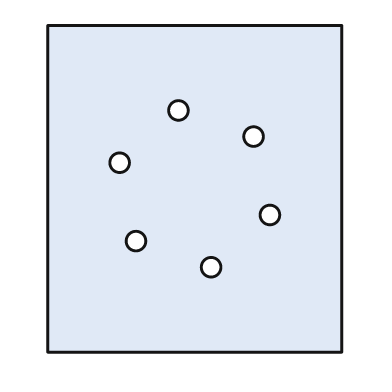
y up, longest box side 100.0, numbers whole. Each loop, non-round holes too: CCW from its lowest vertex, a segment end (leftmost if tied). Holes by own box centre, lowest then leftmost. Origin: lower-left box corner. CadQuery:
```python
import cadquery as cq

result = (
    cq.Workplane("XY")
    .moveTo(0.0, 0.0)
    .lineTo(90.0, 0.0)
    .lineTo(90.0, 100.0)
    .lineTo(0.0, 100.0)
    .close()
    .moveTo(50.0, 26.0)
    .circle(3.0)
    .moveTo(27.0, 34.0)
    .circle(3.0)
    .moveTo(68.0, 42.0)
    .circle(3.0)
    .moveTo(22.0, 58.0)
    .circle(3.0)
    .moveTo(63.0, 66.0)
    .circle(3.0)
    .moveTo(40.0, 74.0)
    .circle(3.0)
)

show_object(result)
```